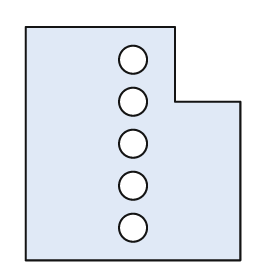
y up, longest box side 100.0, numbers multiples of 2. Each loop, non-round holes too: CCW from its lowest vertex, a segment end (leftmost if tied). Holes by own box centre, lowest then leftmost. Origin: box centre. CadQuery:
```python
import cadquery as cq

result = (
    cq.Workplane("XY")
    .moveTo(-46.0, -50.0)
    .lineTo(46.0, -50.0)
    .lineTo(46.0, 18.0)
    .lineTo(18.0, 18.0)
    .lineTo(18.0, 50.0)
    .lineTo(-46.0, 50.0)
    .close()
    .moveTo(0.0, -36.0)
    .circle(6.0)
    .moveTo(0.0, -18.0)
    .circle(6.0)
    .moveTo(0.0, 0.0)
    .circle(6.0)
    .moveTo(0.0, 18.0)
    .circle(6.0)
    .moveTo(0.0, 36.0)
    .circle(6.0)
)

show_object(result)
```